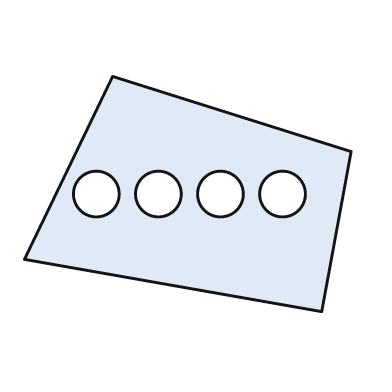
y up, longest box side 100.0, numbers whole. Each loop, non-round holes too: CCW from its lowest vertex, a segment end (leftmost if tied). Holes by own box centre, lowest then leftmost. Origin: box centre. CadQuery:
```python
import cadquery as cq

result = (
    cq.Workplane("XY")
    .moveTo(41.0, -36.0)
    .lineTo(50.0, 13.0)
    .lineTo(-23.0, 36.0)
    .lineTo(-50.0, -20.0)
    .close()
    .moveTo(-28.0, 0.0)
    .circle(7.0)
    .moveTo(-9.0, 0.0)
    .circle(7.0)
    .moveTo(10.0, 0.0)
    .circle(7.0)
    .moveTo(29.0, 0.0)
    .circle(7.0)
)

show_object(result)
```